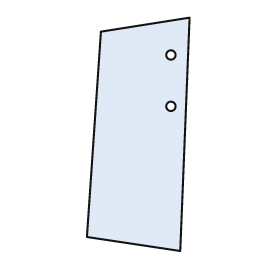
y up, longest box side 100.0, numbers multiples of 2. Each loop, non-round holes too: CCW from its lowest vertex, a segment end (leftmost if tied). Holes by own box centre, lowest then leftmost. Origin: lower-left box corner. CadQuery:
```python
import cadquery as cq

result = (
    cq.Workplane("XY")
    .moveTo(40.0, 0.0)
    .lineTo(44.0, 100.0)
    .lineTo(6.0, 94.0)
    .lineTo(0.0, 6.0)
    .close()
    .moveTo(36.0, 62.0)
    .circle(2.0)
    .moveTo(36.0, 84.0)
    .circle(2.0)
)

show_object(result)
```